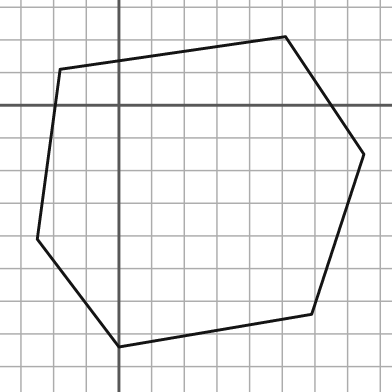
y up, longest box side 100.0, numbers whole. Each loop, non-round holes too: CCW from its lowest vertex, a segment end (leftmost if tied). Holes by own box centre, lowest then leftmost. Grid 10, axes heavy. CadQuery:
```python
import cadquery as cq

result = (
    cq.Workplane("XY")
    .moveTo(0.0, -74.0)
    .lineTo(59.0, -64.0)
    .lineTo(75.0, -15.0)
    .lineTo(51.0, 21.0)
    .lineTo(-18.0, 11.0)
    .lineTo(-25.0, -41.0)
    .close()
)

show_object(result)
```